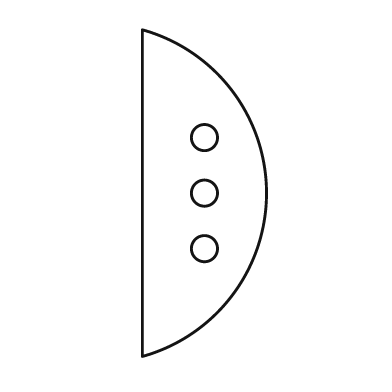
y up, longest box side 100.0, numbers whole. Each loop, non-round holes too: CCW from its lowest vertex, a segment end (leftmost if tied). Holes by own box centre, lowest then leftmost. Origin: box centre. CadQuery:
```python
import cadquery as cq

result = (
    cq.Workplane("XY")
    .moveTo(-19.0, -50.0)
    .threePointArc((19.0, 0.0), (-19.0, 50.0))
    .close()
    .moveTo(0.0, -17.0)
    .circle(4.0)
    .moveTo(0.0, 0.0)
    .circle(4.0)
    .moveTo(0.0, 17.0)
    .circle(4.0)
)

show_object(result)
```